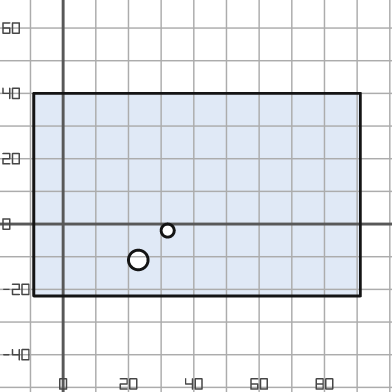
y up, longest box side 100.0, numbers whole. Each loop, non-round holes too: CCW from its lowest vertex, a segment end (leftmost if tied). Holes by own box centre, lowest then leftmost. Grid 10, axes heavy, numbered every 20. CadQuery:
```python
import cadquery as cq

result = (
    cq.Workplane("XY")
    .moveTo(-9.0, -22.0)
    .lineTo(91.0, -22.0)
    .lineTo(91.0, 40.0)
    .lineTo(-9.0, 40.0)
    .close()
    .moveTo(23.0, -11.0)
    .circle(3.0)
    .moveTo(32.0, -2.0)
    .circle(2.0)
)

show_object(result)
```